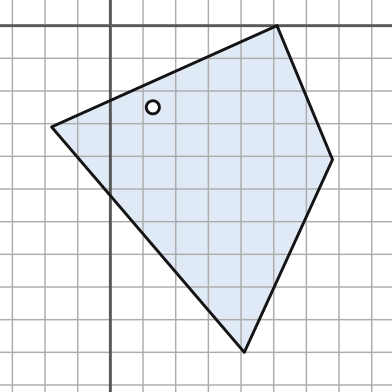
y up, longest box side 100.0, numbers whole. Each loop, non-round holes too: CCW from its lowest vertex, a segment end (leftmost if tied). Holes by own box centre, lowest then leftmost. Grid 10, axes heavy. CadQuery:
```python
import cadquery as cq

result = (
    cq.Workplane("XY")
    .moveTo(41.0, -100.0)
    .lineTo(68.0, -41.0)
    .lineTo(51.0, 0.0)
    .lineTo(-18.0, -31.0)
    .close()
    .moveTo(13.0, -25.0)
    .circle(2.0)
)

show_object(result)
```